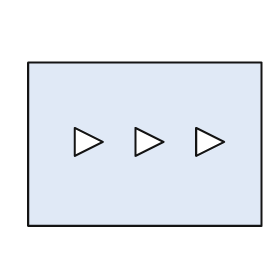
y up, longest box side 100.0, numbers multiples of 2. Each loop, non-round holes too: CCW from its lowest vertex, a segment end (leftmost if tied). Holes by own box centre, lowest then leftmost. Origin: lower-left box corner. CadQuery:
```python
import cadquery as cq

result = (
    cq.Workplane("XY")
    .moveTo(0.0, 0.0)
    .lineTo(100.0, 0.0)
    .lineTo(100.0, 70.0)
    .lineTo(0.0, 70.0)
    .close()
    .moveTo(20.0, 30.0)
    .lineTo(32.0, 36.0)
    .lineTo(20.0, 42.0)
    .close()
    .moveTo(46.0, 30.0)
    .lineTo(58.0, 36.0)
    .lineTo(46.0, 42.0)
    .close()
    .moveTo(72.0, 30.0)
    .lineTo(84.0, 36.0)
    .lineTo(72.0, 42.0)
    .close()
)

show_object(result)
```